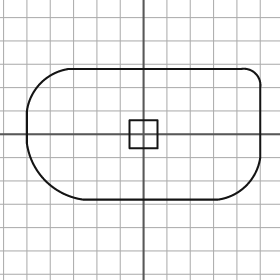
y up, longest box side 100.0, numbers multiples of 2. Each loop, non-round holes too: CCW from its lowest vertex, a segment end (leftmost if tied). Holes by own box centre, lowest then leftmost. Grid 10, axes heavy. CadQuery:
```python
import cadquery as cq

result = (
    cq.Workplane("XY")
    .moveTo(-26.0, -28.0)
    .lineTo(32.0, -28.0)
    .threePointArc((44.0, -22.0), (50.0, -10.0))
    .lineTo(50.0, 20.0)
    .threePointArc((48.0, 26.0), (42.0, 28.0))
    .lineTo(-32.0, 28.0)
    .threePointArc((-44.0, 22.0), (-50.0, 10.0))
    .lineTo(-50.0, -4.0)
    .threePointArc((-42.0, -20.0), (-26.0, -28.0))
    .close()
    .moveTo(-6.0, -6.0)
    .lineTo(6.0, -6.0)
    .lineTo(6.0, 6.0)
    .lineTo(-6.0, 6.0)
    .close()
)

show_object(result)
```